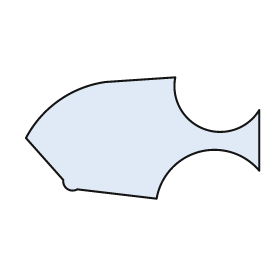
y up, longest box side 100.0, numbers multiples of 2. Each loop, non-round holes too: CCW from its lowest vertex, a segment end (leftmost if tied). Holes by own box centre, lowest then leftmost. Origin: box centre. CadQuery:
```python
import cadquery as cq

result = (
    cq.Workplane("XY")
    .moveTo(6.0, -26.0)
    .threePointArc((24.0, -6.0), (50.0, -14.0))
    .lineTo(50.0, 12.0)
    .threePointArc((26.0, 4.0), (14.0, 26.0))
    .lineTo(-16.0, 24.0)
    .threePointArc((-36.0, 16.0), (-50.0, 0.0))
    .lineTo(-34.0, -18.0)
    .threePointArc((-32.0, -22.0), (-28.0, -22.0))
    .close()
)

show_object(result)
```